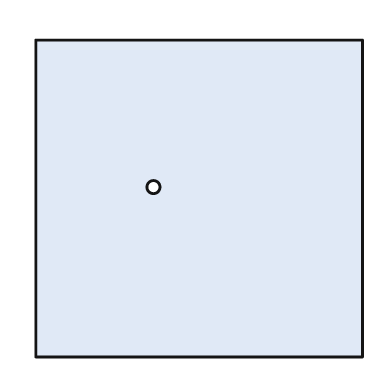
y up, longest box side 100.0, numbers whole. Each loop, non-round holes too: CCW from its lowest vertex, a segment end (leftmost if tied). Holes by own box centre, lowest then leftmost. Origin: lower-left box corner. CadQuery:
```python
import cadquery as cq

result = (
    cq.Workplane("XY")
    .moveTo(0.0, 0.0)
    .lineTo(100.0, 0.0)
    .lineTo(100.0, 97.0)
    .lineTo(0.0, 97.0)
    .close()
    .moveTo(36.0, 52.0)
    .circle(2.0)
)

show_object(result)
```